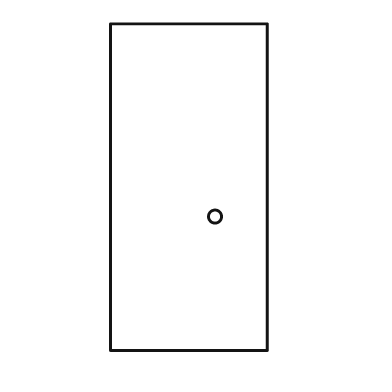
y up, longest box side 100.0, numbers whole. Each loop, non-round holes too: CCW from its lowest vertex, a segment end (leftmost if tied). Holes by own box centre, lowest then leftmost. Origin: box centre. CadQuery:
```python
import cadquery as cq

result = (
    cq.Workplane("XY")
    .moveTo(-24.0, -50.0)
    .lineTo(24.0, -50.0)
    .lineTo(24.0, 50.0)
    .lineTo(-24.0, 50.0)
    .close()
    .moveTo(8.0, -9.0)
    .circle(2.0)
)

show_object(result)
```